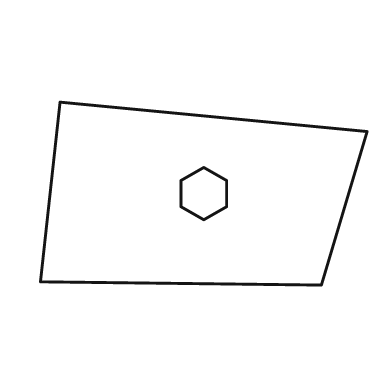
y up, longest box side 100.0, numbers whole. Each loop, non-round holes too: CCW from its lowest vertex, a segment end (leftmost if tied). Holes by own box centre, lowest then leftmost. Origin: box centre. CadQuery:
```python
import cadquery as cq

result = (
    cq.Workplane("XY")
    .moveTo(36.0, -28.0)
    .lineTo(50.0, 19.0)
    .lineTo(-44.0, 28.0)
    .lineTo(-50.0, -27.0)
    .close()
    .moveTo(0.0, -8.0)
    .lineTo(7.0, -4.0)
    .lineTo(7.0, 4.0)
    .lineTo(0.0, 8.0)
    .lineTo(-7.0, 4.0)
    .lineTo(-7.0, -4.0)
    .close()
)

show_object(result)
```